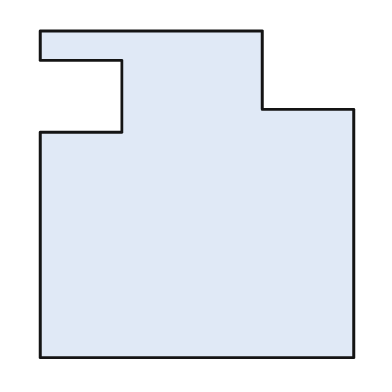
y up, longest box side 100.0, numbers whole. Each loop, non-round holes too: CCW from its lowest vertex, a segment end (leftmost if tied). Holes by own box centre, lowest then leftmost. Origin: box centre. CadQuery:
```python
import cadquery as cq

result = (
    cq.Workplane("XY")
    .moveTo(-48.0, -50.0)
    .lineTo(48.0, -50.0)
    .lineTo(48.0, 26.0)
    .lineTo(20.0, 26.0)
    .lineTo(20.0, 50.0)
    .lineTo(-48.0, 50.0)
    .lineTo(-48.0, 41.0)
    .lineTo(-23.0, 41.0)
    .lineTo(-23.0, 19.0)
    .lineTo(-48.0, 19.0)
    .close()
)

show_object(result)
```